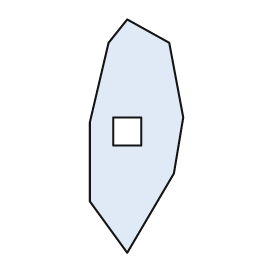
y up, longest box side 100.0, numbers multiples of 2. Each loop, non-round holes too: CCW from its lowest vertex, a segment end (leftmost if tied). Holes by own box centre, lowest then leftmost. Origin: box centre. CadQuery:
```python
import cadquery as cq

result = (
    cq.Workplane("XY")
    .moveTo(-4.0, -50.0)
    .lineTo(16.0, -16.0)
    .lineTo(20.0, 8.0)
    .lineTo(14.0, 40.0)
    .lineTo(-4.0, 50.0)
    .lineTo(-12.0, 40.0)
    .lineTo(-20.0, 6.0)
    .lineTo(-20.0, -28.0)
    .close()
    .moveTo(-10.0, -4.0)
    .lineTo(2.0, -4.0)
    .lineTo(2.0, 8.0)
    .lineTo(-10.0, 8.0)
    .close()
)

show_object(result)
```